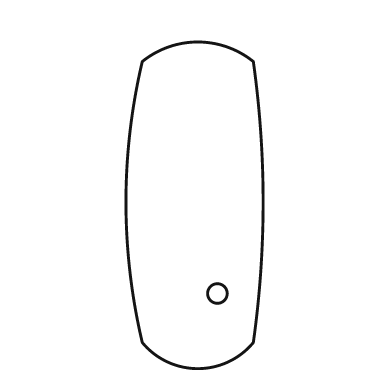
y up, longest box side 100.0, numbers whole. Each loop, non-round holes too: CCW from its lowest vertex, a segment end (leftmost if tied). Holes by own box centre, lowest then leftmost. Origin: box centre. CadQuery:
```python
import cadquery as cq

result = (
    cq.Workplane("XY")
    .moveTo(-16.0, -42.0)
    .threePointArc((1.0, -50.0), (18.0, -42.0))
    .threePointArc((21.0, 1.0), (18.0, 44.0))
    .threePointArc((1.0, 50.0), (-16.0, 44.0))
    .threePointArc((-21.0, 1.0), (-16.0, -42.0))
    .close()
    .moveTo(7.0, -27.0)
    .circle(3.0)
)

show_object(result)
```